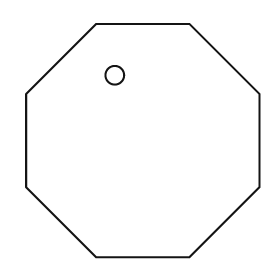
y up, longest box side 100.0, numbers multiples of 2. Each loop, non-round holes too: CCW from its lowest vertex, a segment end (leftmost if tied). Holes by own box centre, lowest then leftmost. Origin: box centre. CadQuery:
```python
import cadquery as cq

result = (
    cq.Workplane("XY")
    .moveTo(-20.0, -50.0)
    .lineTo(20.0, -50.0)
    .lineTo(50.0, -20.0)
    .lineTo(50.0, 20.0)
    .lineTo(20.0, 50.0)
    .lineTo(-20.0, 50.0)
    .lineTo(-50.0, 20.0)
    .lineTo(-50.0, -20.0)
    .close()
    .moveTo(-12.0, 28.0)
    .circle(4.0)
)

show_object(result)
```